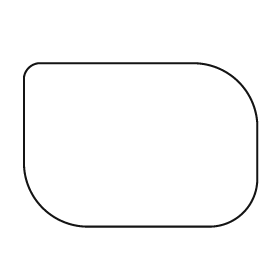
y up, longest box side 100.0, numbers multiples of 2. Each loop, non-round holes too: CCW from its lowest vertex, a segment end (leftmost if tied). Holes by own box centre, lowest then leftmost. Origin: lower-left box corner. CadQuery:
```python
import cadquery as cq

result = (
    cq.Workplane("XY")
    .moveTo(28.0, 0.0)
    .lineTo(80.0, 0.0)
    .threePointArc((94.0, 6.0), (100.0, 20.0))
    .lineTo(100.0, 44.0)
    .threePointArc((92.0, 62.0), (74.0, 70.0))
    .lineTo(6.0, 70.0)
    .threePointArc((2.0, 68.0), (0.0, 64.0))
    .lineTo(0.0, 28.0)
    .threePointArc((8.0, 8.0), (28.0, 0.0))
    .close()
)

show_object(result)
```